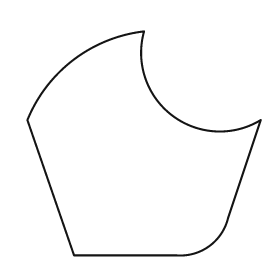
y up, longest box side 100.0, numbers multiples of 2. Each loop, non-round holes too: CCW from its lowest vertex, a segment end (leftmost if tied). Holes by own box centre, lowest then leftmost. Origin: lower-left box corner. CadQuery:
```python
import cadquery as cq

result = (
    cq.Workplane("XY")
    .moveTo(20.0, 0.0)
    .lineTo(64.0, 0.0)
    .threePointArc((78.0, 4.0), (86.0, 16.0))
    .lineTo(100.0, 58.0)
    .threePointArc((62.0, 60.0), (50.0, 96.0))
    .threePointArc((20.0, 84.0), (0.0, 58.0))
    .close()
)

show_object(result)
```